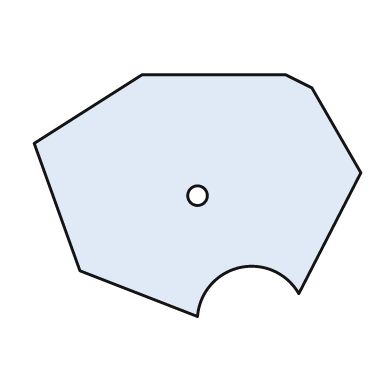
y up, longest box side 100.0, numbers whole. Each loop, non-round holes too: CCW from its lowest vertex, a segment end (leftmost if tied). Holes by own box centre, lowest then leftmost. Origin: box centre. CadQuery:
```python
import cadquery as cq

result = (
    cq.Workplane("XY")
    .moveTo(0.0, -37.0)
    .threePointArc((13.0, -22.0), (31.0, -30.0))
    .lineTo(50.0, 7.0)
    .lineTo(35.0, 33.0)
    .lineTo(27.0, 37.0)
    .lineTo(-17.0, 37.0)
    .lineTo(-50.0, 16.0)
    .lineTo(-36.0, -23.0)
    .close()
    .moveTo(0.0, 0.0)
    .circle(3.0)
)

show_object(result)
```